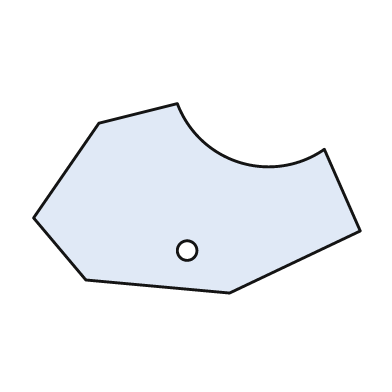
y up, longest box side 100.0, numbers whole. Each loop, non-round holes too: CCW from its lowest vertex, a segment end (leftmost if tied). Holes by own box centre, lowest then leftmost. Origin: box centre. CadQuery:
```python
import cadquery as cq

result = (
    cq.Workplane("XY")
    .moveTo(10.0, -29.0)
    .lineTo(50.0, -10.0)
    .lineTo(39.0, 15.0)
    .threePointArc((13.0, 11.0), (-6.0, 29.0))
    .lineTo(-30.0, 23.0)
    .lineTo(-50.0, -6.0)
    .lineTo(-34.0, -25.0)
    .close()
    .moveTo(-3.0, -16.0)
    .circle(3.0)
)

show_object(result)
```